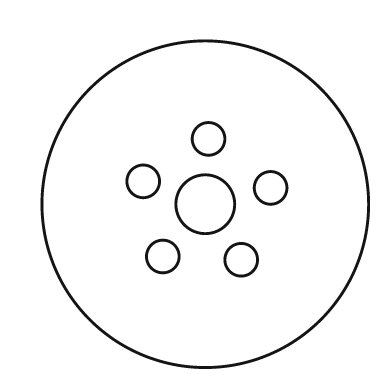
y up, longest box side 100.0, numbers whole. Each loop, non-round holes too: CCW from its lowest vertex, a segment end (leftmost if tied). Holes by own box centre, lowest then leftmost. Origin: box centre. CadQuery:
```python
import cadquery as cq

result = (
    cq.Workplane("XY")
    .moveTo(0.0, 0.0)
    .circle(50.0)
    .moveTo(11.0, -17.0)
    .circle(5.0)
    .moveTo(-13.0, -16.0)
    .circle(5.0)
    .moveTo(0.0, 0.0)
    .circle(9.0)
    .moveTo(20.0, 5.0)
    .circle(5.0)
    .moveTo(-19.0, 7.0)
    .circle(5.0)
    .moveTo(1.0, 20.0)
    .circle(5.0)
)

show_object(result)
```